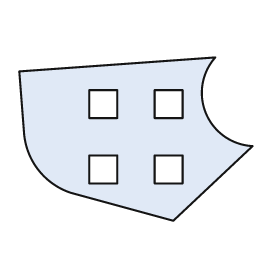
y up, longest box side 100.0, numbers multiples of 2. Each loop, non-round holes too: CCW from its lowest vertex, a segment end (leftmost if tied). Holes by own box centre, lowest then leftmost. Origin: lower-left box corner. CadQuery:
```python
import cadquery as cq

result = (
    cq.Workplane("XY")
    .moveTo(66.0, 0.0)
    .lineTo(100.0, 32.0)
    .threePointArc((80.0, 46.0), (84.0, 70.0))
    .lineTo(0.0, 64.0)
    .lineTo(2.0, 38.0)
    .threePointArc((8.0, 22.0), (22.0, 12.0))
    .close()
    .moveTo(30.0, 16.0)
    .lineTo(42.0, 16.0)
    .lineTo(42.0, 28.0)
    .lineTo(30.0, 28.0)
    .close()
    .moveTo(58.0, 16.0)
    .lineTo(70.0, 16.0)
    .lineTo(70.0, 28.0)
    .lineTo(58.0, 28.0)
    .close()
    .moveTo(30.0, 44.0)
    .lineTo(42.0, 44.0)
    .lineTo(42.0, 56.0)
    .lineTo(30.0, 56.0)
    .close()
    .moveTo(58.0, 44.0)
    .lineTo(70.0, 44.0)
    .lineTo(70.0, 56.0)
    .lineTo(58.0, 56.0)
    .close()
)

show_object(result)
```